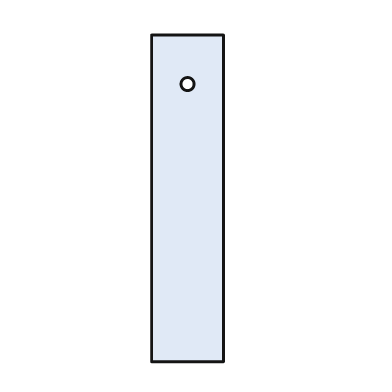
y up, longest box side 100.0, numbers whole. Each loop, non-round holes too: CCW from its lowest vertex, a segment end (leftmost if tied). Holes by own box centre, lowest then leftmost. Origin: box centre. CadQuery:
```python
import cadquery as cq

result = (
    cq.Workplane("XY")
    .moveTo(-11.0, -50.0)
    .lineTo(11.0, -50.0)
    .lineTo(11.0, 50.0)
    .lineTo(-11.0, 50.0)
    .close()
    .moveTo(0.0, 35.0)
    .circle(2.0)
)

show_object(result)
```